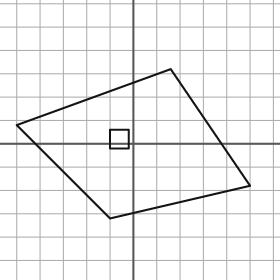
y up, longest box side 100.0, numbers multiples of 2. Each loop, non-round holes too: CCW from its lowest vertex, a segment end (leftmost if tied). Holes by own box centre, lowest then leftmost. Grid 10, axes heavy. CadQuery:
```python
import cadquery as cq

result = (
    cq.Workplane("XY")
    .moveTo(-10.0, -32.0)
    .lineTo(50.0, -18.0)
    .lineTo(16.0, 32.0)
    .lineTo(-50.0, 8.0)
    .close()
    .moveTo(-10.0, -2.0)
    .lineTo(-2.0, -2.0)
    .lineTo(-2.0, 6.0)
    .lineTo(-10.0, 6.0)
    .close()
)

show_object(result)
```